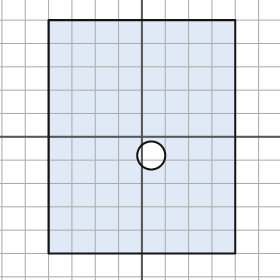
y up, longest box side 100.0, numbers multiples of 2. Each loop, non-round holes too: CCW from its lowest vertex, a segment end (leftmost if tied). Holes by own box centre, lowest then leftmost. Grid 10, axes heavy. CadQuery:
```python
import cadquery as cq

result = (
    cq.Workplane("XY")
    .moveTo(-40.0, -50.0)
    .lineTo(40.0, -50.0)
    .lineTo(40.0, 50.0)
    .lineTo(-40.0, 50.0)
    .close()
    .moveTo(4.0, -8.0)
    .circle(6.0)
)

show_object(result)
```